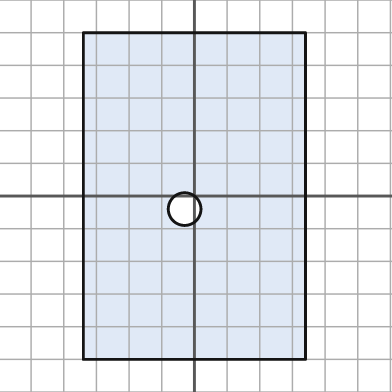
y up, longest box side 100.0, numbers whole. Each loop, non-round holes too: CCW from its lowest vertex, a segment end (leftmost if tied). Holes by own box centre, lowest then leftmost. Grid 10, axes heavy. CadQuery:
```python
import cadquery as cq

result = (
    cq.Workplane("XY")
    .moveTo(-34.0, -50.0)
    .lineTo(34.0, -50.0)
    .lineTo(34.0, 50.0)
    .lineTo(-34.0, 50.0)
    .close()
    .moveTo(-3.0, -4.0)
    .circle(5.0)
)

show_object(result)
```